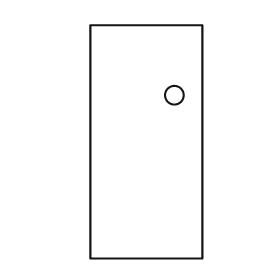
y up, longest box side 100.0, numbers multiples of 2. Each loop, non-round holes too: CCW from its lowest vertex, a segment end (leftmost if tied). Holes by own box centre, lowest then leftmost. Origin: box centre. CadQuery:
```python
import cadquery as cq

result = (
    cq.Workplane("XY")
    .moveTo(-24.0, -50.0)
    .lineTo(24.0, -50.0)
    .lineTo(24.0, 50.0)
    .lineTo(-24.0, 50.0)
    .close()
    .moveTo(12.0, 20.0)
    .circle(4.0)
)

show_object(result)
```